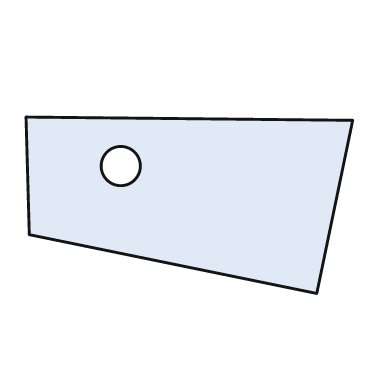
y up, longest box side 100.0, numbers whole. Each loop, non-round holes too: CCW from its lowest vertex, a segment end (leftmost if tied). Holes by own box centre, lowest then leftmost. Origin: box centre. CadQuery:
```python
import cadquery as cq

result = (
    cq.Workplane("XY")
    .moveTo(39.0, -27.0)
    .lineTo(50.0, 26.0)
    .lineTo(-50.0, 27.0)
    .lineTo(-49.0, -9.0)
    .close()
    .moveTo(-21.0, 12.0)
    .circle(6.0)
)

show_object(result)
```